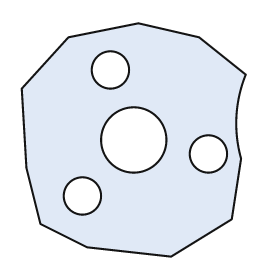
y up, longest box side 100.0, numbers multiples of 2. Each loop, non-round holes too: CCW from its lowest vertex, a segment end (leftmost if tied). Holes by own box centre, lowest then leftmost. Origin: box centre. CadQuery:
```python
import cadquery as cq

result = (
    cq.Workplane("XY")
    .moveTo(16.0, -50.0)
    .lineTo(42.0, -34.0)
    .lineTo(46.0, -8.0)
    .threePointArc((44.0, 10.0), (48.0, 28.0))
    .lineTo(28.0, 44.0)
    .lineTo(2.0, 50.0)
    .lineTo(-28.0, 44.0)
    .lineTo(-48.0, 22.0)
    .lineTo(-46.0, -12.0)
    .lineTo(-40.0, -36.0)
    .lineTo(-20.0, -46.0)
    .close()
    .moveTo(-22.0, -24.0)
    .circle(8.0)
    .moveTo(32.0, -6.0)
    .circle(8.0)
    .moveTo(0.0, 0.0)
    .circle(14.0)
    .moveTo(-10.0, 30.0)
    .circle(8.0)
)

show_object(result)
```